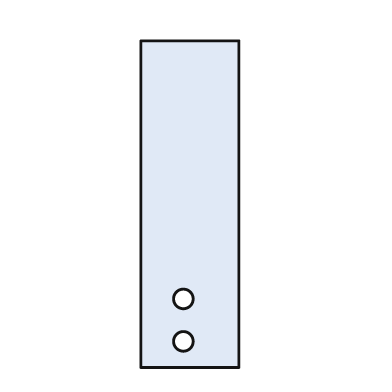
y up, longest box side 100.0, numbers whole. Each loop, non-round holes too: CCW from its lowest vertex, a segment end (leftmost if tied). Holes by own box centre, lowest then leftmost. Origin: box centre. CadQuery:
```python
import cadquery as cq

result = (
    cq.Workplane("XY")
    .moveTo(-15.0, -50.0)
    .lineTo(15.0, -50.0)
    .lineTo(15.0, 50.0)
    .lineTo(-15.0, 50.0)
    .close()
    .moveTo(-2.0, -42.0)
    .circle(3.0)
    .moveTo(-2.0, -29.0)
    .circle(3.0)
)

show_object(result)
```